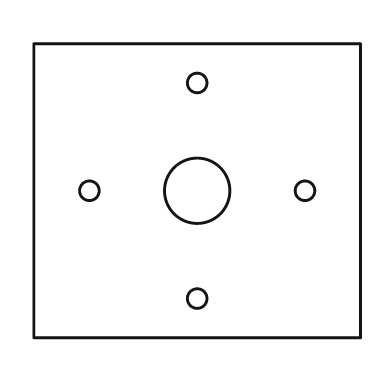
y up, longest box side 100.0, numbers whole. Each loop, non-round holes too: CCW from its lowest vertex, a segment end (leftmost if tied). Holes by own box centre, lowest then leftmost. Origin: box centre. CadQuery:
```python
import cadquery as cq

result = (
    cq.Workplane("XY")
    .moveTo(-50.0, -45.0)
    .lineTo(50.0, -45.0)
    .lineTo(50.0, 45.0)
    .lineTo(-50.0, 45.0)
    .close()
    .moveTo(0.0, -33.0)
    .circle(3.0)
    .moveTo(-33.0, 0.0)
    .circle(3.0)
    .moveTo(0.0, 0.0)
    .circle(10.0)
    .moveTo(33.0, 0.0)
    .circle(3.0)
    .moveTo(0.0, 33.0)
    .circle(3.0)
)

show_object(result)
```